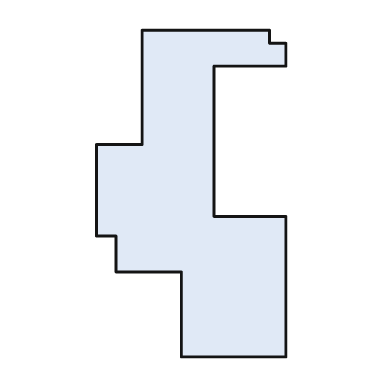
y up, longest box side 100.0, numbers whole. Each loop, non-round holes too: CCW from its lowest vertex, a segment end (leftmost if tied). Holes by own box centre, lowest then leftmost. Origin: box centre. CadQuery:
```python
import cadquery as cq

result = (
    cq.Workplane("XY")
    .moveTo(-3.0, -50.0)
    .lineTo(29.0, -50.0)
    .lineTo(29.0, -7.0)
    .lineTo(7.0, -7.0)
    .lineTo(7.0, 39.0)
    .lineTo(29.0, 39.0)
    .lineTo(29.0, 46.0)
    .lineTo(24.0, 46.0)
    .lineTo(24.0, 50.0)
    .lineTo(-15.0, 50.0)
    .lineTo(-15.0, 15.0)
    .lineTo(-29.0, 15.0)
    .lineTo(-29.0, -13.0)
    .lineTo(-23.0, -13.0)
    .lineTo(-23.0, -24.0)
    .lineTo(-3.0, -24.0)
    .close()
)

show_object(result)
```